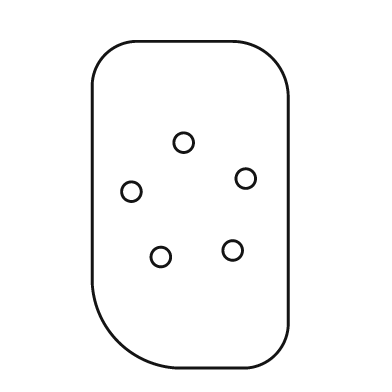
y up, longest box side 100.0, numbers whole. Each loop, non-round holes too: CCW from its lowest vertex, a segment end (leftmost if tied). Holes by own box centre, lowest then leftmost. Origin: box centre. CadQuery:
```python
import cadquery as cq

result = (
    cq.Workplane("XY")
    .moveTo(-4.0, -50.0)
    .lineTo(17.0, -50.0)
    .threePointArc((26.0, -46.0), (30.0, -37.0))
    .lineTo(30.0, 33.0)
    .threePointArc((25.0, 45.0), (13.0, 50.0))
    .lineTo(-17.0, 50.0)
    .threePointArc((-26.0, 46.0), (-30.0, 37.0))
    .lineTo(-30.0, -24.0)
    .threePointArc((-22.0, -42.0), (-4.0, -50.0))
    .close()
    .moveTo(-9.0, -16.0)
    .circle(3.0)
    .moveTo(13.0, -14.0)
    .circle(3.0)
    .moveTo(-18.0, 4.0)
    .circle(3.0)
    .moveTo(17.0, 8.0)
    .circle(3.0)
    .moveTo(-2.0, 19.0)
    .circle(3.0)
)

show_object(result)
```